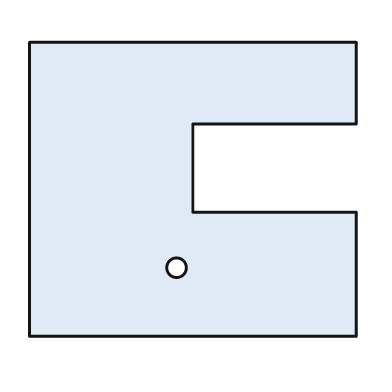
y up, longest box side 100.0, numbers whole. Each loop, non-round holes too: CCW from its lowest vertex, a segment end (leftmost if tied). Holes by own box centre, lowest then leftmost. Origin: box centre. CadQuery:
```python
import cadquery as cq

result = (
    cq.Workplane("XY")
    .moveTo(-50.0, -45.0)
    .lineTo(50.0, -45.0)
    .lineTo(50.0, -7.0)
    .lineTo(0.0, -7.0)
    .lineTo(0.0, 20.0)
    .lineTo(50.0, 20.0)
    .lineTo(50.0, 45.0)
    .lineTo(-50.0, 45.0)
    .close()
    .moveTo(-5.0, -24.0)
    .circle(3.0)
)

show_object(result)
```